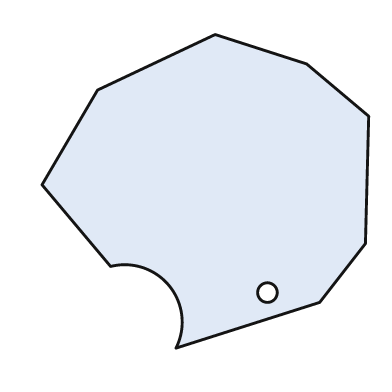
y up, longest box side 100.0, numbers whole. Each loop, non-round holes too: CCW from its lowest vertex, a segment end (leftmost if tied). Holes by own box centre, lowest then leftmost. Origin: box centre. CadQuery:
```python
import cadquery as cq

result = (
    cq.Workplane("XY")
    .moveTo(-9.0, -48.0)
    .lineTo(35.0, -34.0)
    .lineTo(49.0, -16.0)
    .lineTo(50.0, 23.0)
    .lineTo(31.0, 39.0)
    .lineTo(3.0, 48.0)
    .lineTo(-33.0, 31.0)
    .lineTo(-50.0, 2.0)
    .lineTo(-29.0, -23.0)
    .threePointArc((-11.0, -29.0), (-9.0, -48.0))
    .close()
    .moveTo(19.0, -31.0)
    .circle(3.0)
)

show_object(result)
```